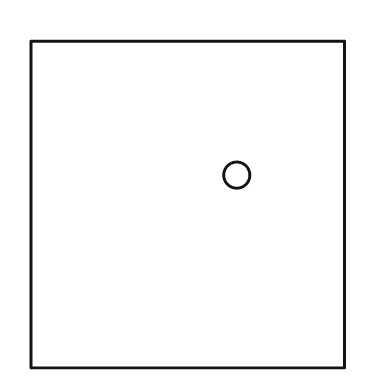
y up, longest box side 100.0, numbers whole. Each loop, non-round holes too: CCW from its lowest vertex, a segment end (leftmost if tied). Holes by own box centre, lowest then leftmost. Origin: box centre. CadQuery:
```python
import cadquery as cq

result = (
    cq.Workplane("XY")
    .moveTo(-48.0, -50.0)
    .lineTo(48.0, -50.0)
    .lineTo(48.0, 50.0)
    .lineTo(-48.0, 50.0)
    .close()
    .moveTo(15.0, 9.0)
    .circle(4.0)
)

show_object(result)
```